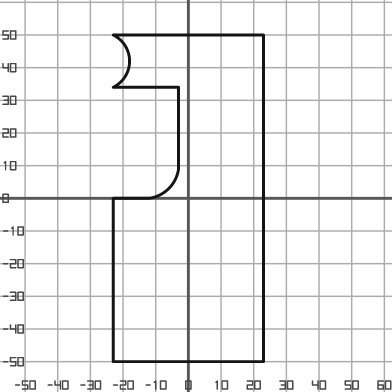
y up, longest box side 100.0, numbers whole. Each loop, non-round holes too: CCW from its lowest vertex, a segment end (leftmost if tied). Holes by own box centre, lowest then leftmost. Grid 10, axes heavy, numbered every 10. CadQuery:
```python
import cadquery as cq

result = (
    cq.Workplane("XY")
    .moveTo(-23.0, -50.0)
    .lineTo(23.0, -50.0)
    .lineTo(23.0, 50.0)
    .lineTo(-23.0, 50.0)
    .threePointArc((-18.0, 42.0), (-23.0, 34.0))
    .lineTo(-3.0, 34.0)
    .lineTo(-3.0, 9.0)
    .threePointArc((-6.0, 3.0), (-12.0, 0.0))
    .lineTo(-23.0, 0.0)
    .close()
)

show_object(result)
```